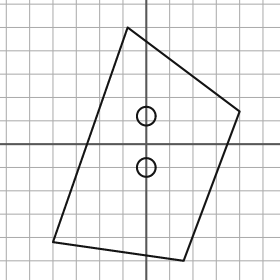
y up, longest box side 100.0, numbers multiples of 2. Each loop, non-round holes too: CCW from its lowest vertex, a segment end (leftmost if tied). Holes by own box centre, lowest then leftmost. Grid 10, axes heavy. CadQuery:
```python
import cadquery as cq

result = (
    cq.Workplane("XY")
    .moveTo(16.0, -50.0)
    .lineTo(40.0, 14.0)
    .lineTo(-8.0, 50.0)
    .lineTo(-40.0, -42.0)
    .close()
    .moveTo(0.0, -10.0)
    .circle(4.0)
    .moveTo(0.0, 12.0)
    .circle(4.0)
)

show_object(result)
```